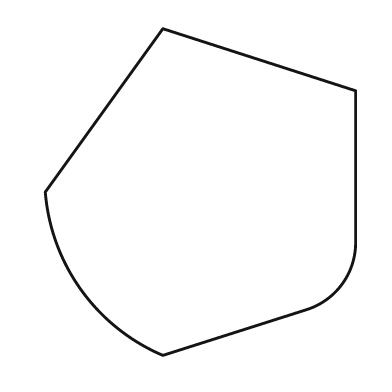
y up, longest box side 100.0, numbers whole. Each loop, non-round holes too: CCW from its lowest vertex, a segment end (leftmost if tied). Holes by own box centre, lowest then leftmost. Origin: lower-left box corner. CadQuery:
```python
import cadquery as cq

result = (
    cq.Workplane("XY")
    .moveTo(36.0, 0.0)
    .lineTo(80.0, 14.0)
    .threePointArc((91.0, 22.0), (95.0, 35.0))
    .lineTo(95.0, 81.0)
    .lineTo(36.0, 100.0)
    .lineTo(0.0, 50.0)
    .threePointArc((11.0, 20.0), (36.0, 0.0))
    .close()
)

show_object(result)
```